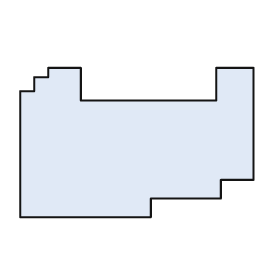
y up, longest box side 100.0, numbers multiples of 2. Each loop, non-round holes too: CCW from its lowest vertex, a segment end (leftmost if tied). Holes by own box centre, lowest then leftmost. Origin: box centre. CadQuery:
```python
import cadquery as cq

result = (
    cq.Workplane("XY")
    .moveTo(-50.0, -32.0)
    .lineTo(6.0, -32.0)
    .lineTo(6.0, -24.0)
    .lineTo(36.0, -24.0)
    .lineTo(36.0, -16.0)
    .lineTo(50.0, -16.0)
    .lineTo(50.0, 32.0)
    .lineTo(34.0, 32.0)
    .lineTo(34.0, 18.0)
    .lineTo(-24.0, 18.0)
    .lineTo(-24.0, 32.0)
    .lineTo(-38.0, 32.0)
    .lineTo(-38.0, 28.0)
    .lineTo(-44.0, 28.0)
    .lineTo(-44.0, 22.0)
    .lineTo(-50.0, 22.0)
    .close()
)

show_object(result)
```